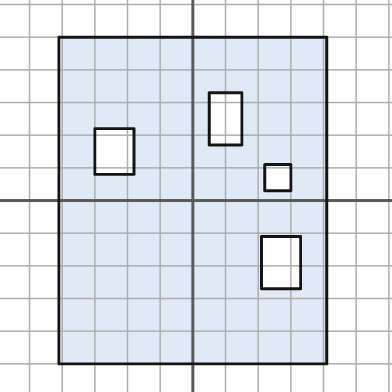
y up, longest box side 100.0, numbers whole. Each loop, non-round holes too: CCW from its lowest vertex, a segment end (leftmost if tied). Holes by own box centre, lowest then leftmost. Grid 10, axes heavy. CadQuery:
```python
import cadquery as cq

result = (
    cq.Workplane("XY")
    .moveTo(-41.0, -50.0)
    .lineTo(41.0, -50.0)
    .lineTo(41.0, 50.0)
    .lineTo(-41.0, 50.0)
    .close()
    .moveTo(21.0, -27.0)
    .lineTo(33.0, -27.0)
    .lineTo(33.0, -11.0)
    .lineTo(21.0, -11.0)
    .close()
    .moveTo(22.0, 3.0)
    .lineTo(30.0, 3.0)
    .lineTo(30.0, 11.0)
    .lineTo(22.0, 11.0)
    .close()
    .moveTo(-30.0, 8.0)
    .lineTo(-18.0, 8.0)
    .lineTo(-18.0, 22.0)
    .lineTo(-30.0, 22.0)
    .close()
    .moveTo(5.0, 17.0)
    .lineTo(15.0, 17.0)
    .lineTo(15.0, 33.0)
    .lineTo(5.0, 33.0)
    .close()
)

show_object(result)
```